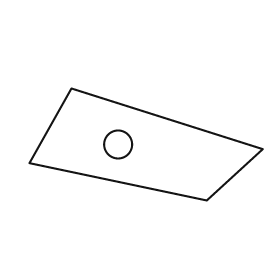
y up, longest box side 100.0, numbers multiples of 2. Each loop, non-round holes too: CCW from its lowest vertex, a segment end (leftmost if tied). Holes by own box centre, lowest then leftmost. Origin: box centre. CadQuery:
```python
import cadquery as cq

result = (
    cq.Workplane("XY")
    .moveTo(26.0, -24.0)
    .lineTo(50.0, -2.0)
    .lineTo(-32.0, 24.0)
    .lineTo(-50.0, -8.0)
    .close()
    .moveTo(-12.0, 0.0)
    .circle(6.0)
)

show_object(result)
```